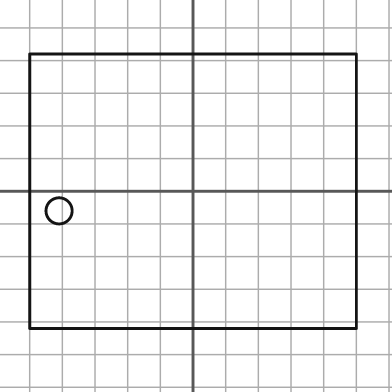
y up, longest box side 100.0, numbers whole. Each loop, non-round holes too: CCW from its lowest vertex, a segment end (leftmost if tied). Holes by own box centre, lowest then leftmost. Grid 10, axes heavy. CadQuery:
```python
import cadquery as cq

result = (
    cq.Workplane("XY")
    .moveTo(-50.0, -42.0)
    .lineTo(50.0, -42.0)
    .lineTo(50.0, 42.0)
    .lineTo(-50.0, 42.0)
    .close()
    .moveTo(-41.0, -6.0)
    .circle(4.0)
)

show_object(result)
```